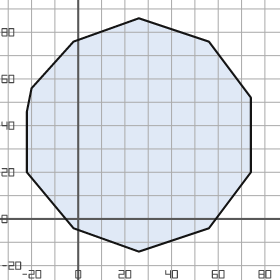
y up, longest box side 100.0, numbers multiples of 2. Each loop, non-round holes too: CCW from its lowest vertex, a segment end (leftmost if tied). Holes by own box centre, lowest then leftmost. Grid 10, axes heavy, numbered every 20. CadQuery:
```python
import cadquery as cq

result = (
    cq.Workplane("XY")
    .moveTo(26.0, -14.0)
    .lineTo(56.0, -4.0)
    .lineTo(74.0, 20.0)
    .lineTo(74.0, 52.0)
    .lineTo(56.0, 76.0)
    .lineTo(26.0, 86.0)
    .lineTo(-2.0, 76.0)
    .lineTo(-20.0, 56.0)
    .lineTo(-22.0, 46.0)
    .lineTo(-22.0, 20.0)
    .lineTo(-2.0, -4.0)
    .close()
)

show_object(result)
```